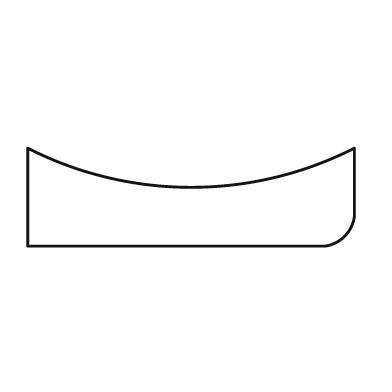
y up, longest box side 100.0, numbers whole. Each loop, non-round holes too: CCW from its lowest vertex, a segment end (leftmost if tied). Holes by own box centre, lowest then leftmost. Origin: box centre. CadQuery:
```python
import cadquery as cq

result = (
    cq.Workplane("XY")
    .moveTo(-50.0, -15.0)
    .lineTo(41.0, -15.0)
    .threePointArc((47.0, -12.0), (50.0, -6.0))
    .lineTo(50.0, 15.0)
    .threePointArc((0.0, 3.0), (-50.0, 15.0))
    .close()
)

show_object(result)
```